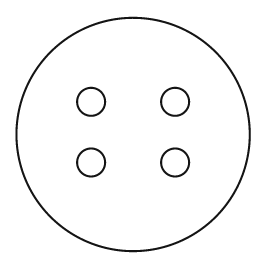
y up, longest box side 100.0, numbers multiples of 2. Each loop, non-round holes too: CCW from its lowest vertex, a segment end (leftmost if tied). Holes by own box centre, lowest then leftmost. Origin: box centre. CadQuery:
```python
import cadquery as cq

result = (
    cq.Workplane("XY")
    .moveTo(0.0, 0.0)
    .circle(50.0)
    .moveTo(-18.0, -12.0)
    .circle(6.0)
    .moveTo(18.0, -12.0)
    .circle(6.0)
    .moveTo(-18.0, 14.0)
    .circle(6.0)
    .moveTo(18.0, 14.0)
    .circle(6.0)
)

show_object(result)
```